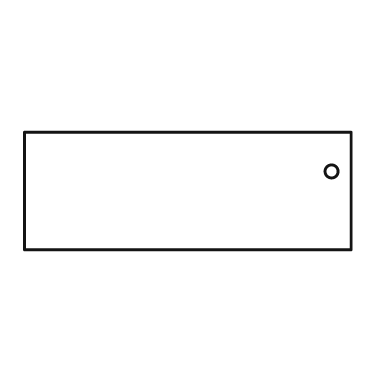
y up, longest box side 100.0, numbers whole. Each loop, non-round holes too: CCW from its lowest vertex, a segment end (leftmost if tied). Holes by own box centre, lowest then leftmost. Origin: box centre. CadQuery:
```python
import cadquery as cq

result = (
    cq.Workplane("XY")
    .moveTo(-50.0, -18.0)
    .lineTo(50.0, -18.0)
    .lineTo(50.0, 18.0)
    .lineTo(-50.0, 18.0)
    .close()
    .moveTo(44.0, 6.0)
    .circle(2.0)
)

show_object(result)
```